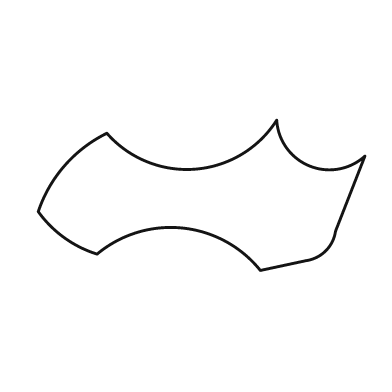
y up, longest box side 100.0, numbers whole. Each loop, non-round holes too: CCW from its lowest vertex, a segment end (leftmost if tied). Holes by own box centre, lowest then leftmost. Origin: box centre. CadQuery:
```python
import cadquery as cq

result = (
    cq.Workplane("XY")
    .moveTo(18.0, -23.0)
    .lineTo(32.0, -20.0)
    .threePointArc((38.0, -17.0), (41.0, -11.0))
    .lineTo(50.0, 12.0)
    .threePointArc((33.0, 9.0), (23.0, 23.0))
    .threePointArc((-2.0, 8.0), (-29.0, 19.0))
    .threePointArc((-42.0, 9.0), (-50.0, -5.0))
    .threePointArc((-42.0, -13.0), (-32.0, -18.0))
    .threePointArc((-6.0, -10.0), (18.0, -23.0))
    .close()
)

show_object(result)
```